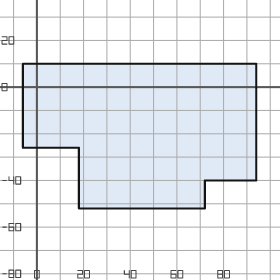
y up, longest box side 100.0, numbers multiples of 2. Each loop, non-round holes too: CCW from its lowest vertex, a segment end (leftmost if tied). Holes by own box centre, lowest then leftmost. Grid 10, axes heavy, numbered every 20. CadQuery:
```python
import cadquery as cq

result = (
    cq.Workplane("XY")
    .moveTo(18.0, -52.0)
    .lineTo(72.0, -52.0)
    .lineTo(72.0, -40.0)
    .lineTo(94.0, -40.0)
    .lineTo(94.0, 10.0)
    .lineTo(-6.0, 10.0)
    .lineTo(-6.0, -26.0)
    .lineTo(18.0, -26.0)
    .close()
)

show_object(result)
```